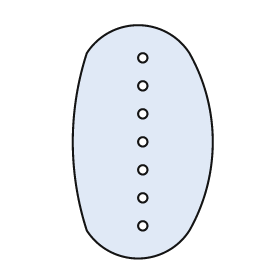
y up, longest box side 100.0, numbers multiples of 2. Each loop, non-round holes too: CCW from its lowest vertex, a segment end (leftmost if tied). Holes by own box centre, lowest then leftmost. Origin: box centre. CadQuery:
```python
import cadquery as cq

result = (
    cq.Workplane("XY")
    .moveTo(-24.0, -38.0)
    .threePointArc((-2.0, -50.0), (20.0, -38.0))
    .threePointArc((30.0, 0.0), (20.0, 38.0))
    .threePointArc((-2.0, 50.0), (-24.0, 38.0))
    .threePointArc((-30.0, 0.0), (-24.0, -38.0))
    .close()
    .moveTo(0.0, -36.0)
    .circle(2.0)
    .moveTo(0.0, -24.0)
    .circle(2.0)
    .moveTo(0.0, -12.0)
    .circle(2.0)
    .moveTo(0.0, 0.0)
    .circle(2.0)
    .moveTo(0.0, 12.0)
    .circle(2.0)
    .moveTo(0.0, 24.0)
    .circle(2.0)
    .moveTo(0.0, 36.0)
    .circle(2.0)
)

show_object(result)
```